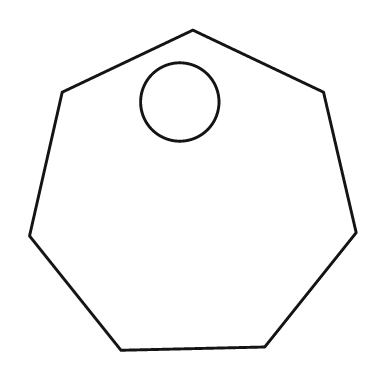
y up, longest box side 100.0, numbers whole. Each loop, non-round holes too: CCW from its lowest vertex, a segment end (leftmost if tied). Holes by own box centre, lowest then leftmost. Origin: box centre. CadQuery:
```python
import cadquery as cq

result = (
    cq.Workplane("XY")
    .moveTo(-22.0, -49.0)
    .lineTo(22.0, -48.0)
    .lineTo(50.0, -13.0)
    .lineTo(40.0, 30.0)
    .lineTo(0.0, 49.0)
    .lineTo(-40.0, 30.0)
    .lineTo(-50.0, -14.0)
    .close()
    .moveTo(-4.0, 27.0)
    .circle(12.0)
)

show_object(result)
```